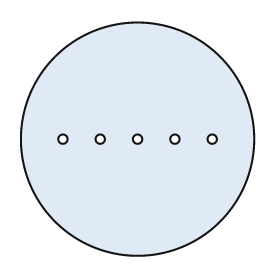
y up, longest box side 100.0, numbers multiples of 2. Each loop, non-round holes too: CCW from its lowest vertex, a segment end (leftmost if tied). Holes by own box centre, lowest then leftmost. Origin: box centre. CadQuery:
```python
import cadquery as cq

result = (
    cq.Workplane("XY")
    .moveTo(0.0, 0.0)
    .circle(50.0)
    .moveTo(-32.0, 0.0)
    .circle(2.0)
    .moveTo(-16.0, 0.0)
    .circle(2.0)
    .moveTo(0.0, 0.0)
    .circle(2.0)
    .moveTo(16.0, 0.0)
    .circle(2.0)
    .moveTo(32.0, 0.0)
    .circle(2.0)
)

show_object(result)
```